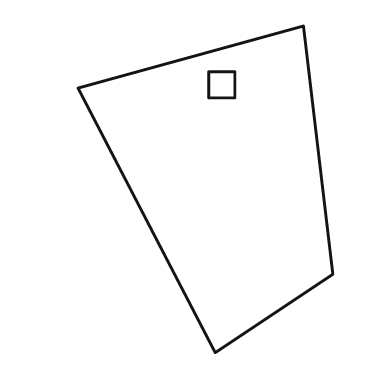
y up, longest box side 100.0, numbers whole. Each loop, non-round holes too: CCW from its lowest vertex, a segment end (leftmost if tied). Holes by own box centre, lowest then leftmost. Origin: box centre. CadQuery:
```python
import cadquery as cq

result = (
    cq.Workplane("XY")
    .moveTo(3.0, -50.0)
    .lineTo(39.0, -26.0)
    .lineTo(30.0, 50.0)
    .lineTo(-39.0, 31.0)
    .close()
    .moveTo(1.0, 28.0)
    .lineTo(9.0, 28.0)
    .lineTo(9.0, 36.0)
    .lineTo(1.0, 36.0)
    .close()
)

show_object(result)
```